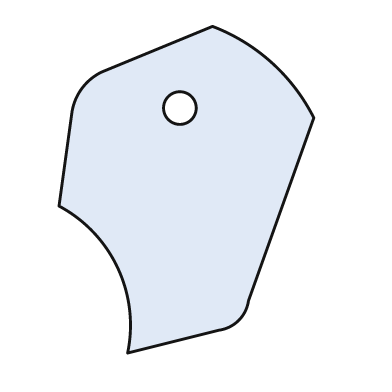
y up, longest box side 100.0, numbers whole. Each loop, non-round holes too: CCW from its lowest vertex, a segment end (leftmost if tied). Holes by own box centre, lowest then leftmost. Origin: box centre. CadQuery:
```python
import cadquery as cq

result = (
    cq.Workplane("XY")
    .moveTo(-18.0, -50.0)
    .lineTo(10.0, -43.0)
    .threePointArc((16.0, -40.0), (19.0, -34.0))
    .lineTo(39.0, 22.0)
    .threePointArc((26.0, 39.0), (8.0, 50.0))
    .lineTo(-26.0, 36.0)
    .threePointArc((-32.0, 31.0), (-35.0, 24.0))
    .lineTo(-39.0, -5.0)
    .threePointArc((-21.0, -24.0), (-18.0, -50.0))
    .close()
    .moveTo(-2.0, 25.0)
    .circle(5.0)
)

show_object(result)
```